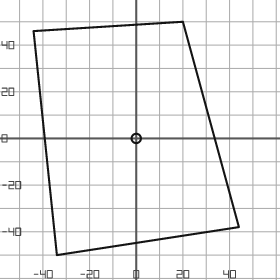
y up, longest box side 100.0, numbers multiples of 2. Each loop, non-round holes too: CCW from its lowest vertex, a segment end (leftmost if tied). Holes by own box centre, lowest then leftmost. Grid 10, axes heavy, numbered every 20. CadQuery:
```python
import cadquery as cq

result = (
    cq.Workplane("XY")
    .moveTo(-34.0, -50.0)
    .lineTo(44.0, -38.0)
    .lineTo(20.0, 50.0)
    .lineTo(-44.0, 46.0)
    .close()
    .moveTo(0.0, 0.0)
    .circle(2.0)
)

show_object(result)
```